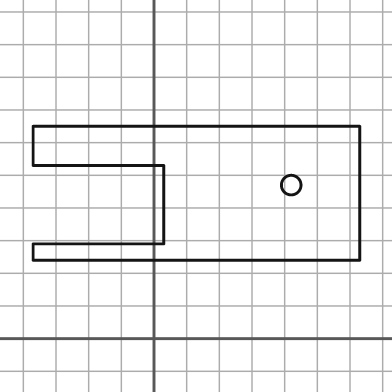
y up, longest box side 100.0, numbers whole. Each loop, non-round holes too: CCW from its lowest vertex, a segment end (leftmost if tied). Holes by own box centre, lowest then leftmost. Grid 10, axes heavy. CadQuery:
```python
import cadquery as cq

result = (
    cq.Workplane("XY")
    .moveTo(-37.0, 24.0)
    .lineTo(63.0, 24.0)
    .lineTo(63.0, 65.0)
    .lineTo(-37.0, 65.0)
    .lineTo(-37.0, 53.0)
    .lineTo(3.0, 53.0)
    .lineTo(3.0, 29.0)
    .lineTo(-37.0, 29.0)
    .close()
    .moveTo(42.0, 47.0)
    .circle(3.0)
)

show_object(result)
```